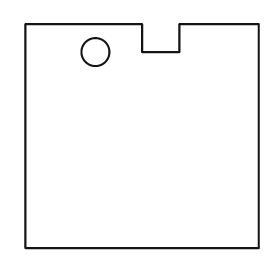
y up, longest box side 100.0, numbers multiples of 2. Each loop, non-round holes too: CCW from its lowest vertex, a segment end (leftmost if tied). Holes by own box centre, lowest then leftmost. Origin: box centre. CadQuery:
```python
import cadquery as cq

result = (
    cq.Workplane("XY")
    .moveTo(-50.0, -48.0)
    .lineTo(50.0, -48.0)
    .lineTo(50.0, 48.0)
    .lineTo(16.0, 48.0)
    .lineTo(16.0, 36.0)
    .lineTo(0.0, 36.0)
    .lineTo(0.0, 48.0)
    .lineTo(-50.0, 48.0)
    .close()
    .moveTo(-20.0, 36.0)
    .circle(6.0)
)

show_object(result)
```